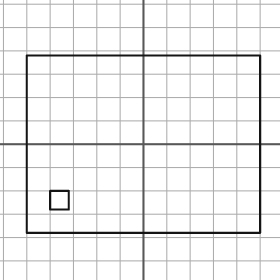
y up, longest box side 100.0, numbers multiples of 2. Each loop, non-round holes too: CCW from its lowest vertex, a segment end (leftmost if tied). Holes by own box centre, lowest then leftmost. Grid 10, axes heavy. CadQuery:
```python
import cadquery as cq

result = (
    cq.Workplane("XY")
    .moveTo(-50.0, -38.0)
    .lineTo(50.0, -38.0)
    .lineTo(50.0, 38.0)
    .lineTo(-50.0, 38.0)
    .close()
    .moveTo(-40.0, -28.0)
    .lineTo(-32.0, -28.0)
    .lineTo(-32.0, -20.0)
    .lineTo(-40.0, -20.0)
    .close()
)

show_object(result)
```